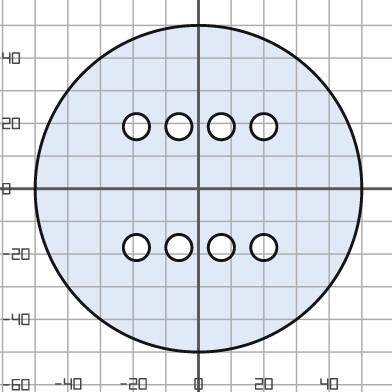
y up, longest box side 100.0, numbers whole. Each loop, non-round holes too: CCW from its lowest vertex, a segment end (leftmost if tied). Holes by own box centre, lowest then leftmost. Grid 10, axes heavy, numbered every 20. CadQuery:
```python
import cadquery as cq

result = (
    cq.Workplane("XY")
    .moveTo(0.0, 0.0)
    .circle(50.0)
    .moveTo(-19.0, -18.0)
    .circle(4.0)
    .moveTo(-6.0, -18.0)
    .circle(4.0)
    .moveTo(7.0, -18.0)
    .circle(4.0)
    .moveTo(20.0, -18.0)
    .circle(4.0)
    .moveTo(-19.0, 19.0)
    .circle(4.0)
    .moveTo(-6.0, 19.0)
    .circle(4.0)
    .moveTo(7.0, 19.0)
    .circle(4.0)
    .moveTo(20.0, 19.0)
    .circle(4.0)
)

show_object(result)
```